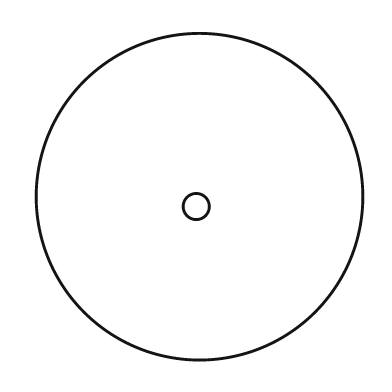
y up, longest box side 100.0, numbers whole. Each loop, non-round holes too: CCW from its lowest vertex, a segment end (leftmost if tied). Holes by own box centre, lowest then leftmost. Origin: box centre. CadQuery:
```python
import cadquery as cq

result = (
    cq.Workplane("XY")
    .moveTo(0.0, 0.0)
    .circle(50.0)
    .moveTo(-1.0, -3.0)
    .circle(4.0)
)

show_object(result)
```